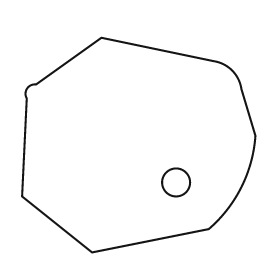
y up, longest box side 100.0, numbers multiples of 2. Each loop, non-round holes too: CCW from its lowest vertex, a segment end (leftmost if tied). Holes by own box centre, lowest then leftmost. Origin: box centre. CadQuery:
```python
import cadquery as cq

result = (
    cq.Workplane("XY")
    .moveTo(-20.0, -46.0)
    .lineTo(30.0, -36.0)
    .threePointArc((44.0, -18.0), (50.0, 4.0))
    .lineTo(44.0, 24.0)
    .threePointArc((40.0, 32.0), (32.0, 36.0))
    .lineTo(-16.0, 46.0)
    .lineTo(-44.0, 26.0)
    .threePointArc((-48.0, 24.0), (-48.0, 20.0))
    .lineTo(-50.0, -22.0)
    .close()
    .moveTo(16.0, -16.0)
    .circle(6.0)
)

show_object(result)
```